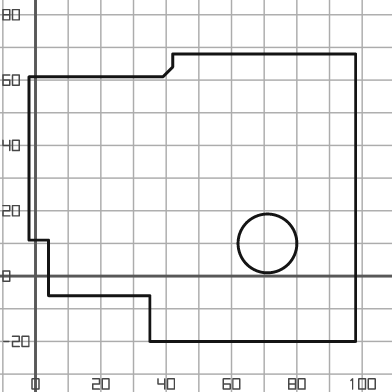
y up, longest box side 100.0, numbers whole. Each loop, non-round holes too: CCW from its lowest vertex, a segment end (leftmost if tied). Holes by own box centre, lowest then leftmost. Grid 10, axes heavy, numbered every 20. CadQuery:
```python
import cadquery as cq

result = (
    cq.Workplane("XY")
    .moveTo(35.0, -20.0)
    .lineTo(98.0, -20.0)
    .lineTo(98.0, 68.0)
    .lineTo(42.0, 68.0)
    .lineTo(42.0, 64.0)
    .lineTo(39.0, 61.0)
    .lineTo(-2.0, 61.0)
    .lineTo(-2.0, 11.0)
    .lineTo(4.0, 11.0)
    .lineTo(4.0, -6.0)
    .lineTo(35.0, -6.0)
    .close()
    .moveTo(71.0, 10.0)
    .circle(9.0)
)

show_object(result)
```